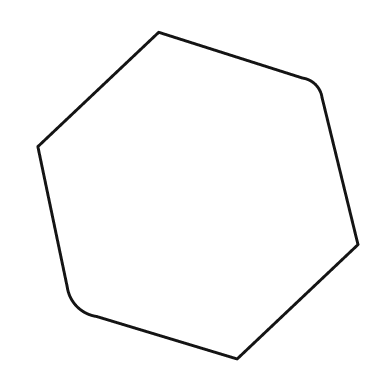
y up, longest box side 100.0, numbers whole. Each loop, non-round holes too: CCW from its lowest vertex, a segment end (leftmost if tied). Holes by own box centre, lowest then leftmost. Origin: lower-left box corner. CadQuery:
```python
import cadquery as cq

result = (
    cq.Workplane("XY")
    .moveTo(61.0, 0.0)
    .lineTo(98.0, 35.0)
    .lineTo(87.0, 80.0)
    .threePointArc((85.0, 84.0), (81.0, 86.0))
    .lineTo(37.0, 100.0)
    .lineTo(0.0, 65.0)
    .lineTo(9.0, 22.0)
    .threePointArc((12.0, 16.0), (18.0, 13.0))
    .close()
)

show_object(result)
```